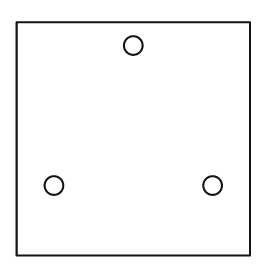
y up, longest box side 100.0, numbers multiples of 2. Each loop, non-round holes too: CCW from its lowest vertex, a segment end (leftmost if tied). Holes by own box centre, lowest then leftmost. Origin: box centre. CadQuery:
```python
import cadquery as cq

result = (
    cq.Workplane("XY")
    .moveTo(-50.0, -50.0)
    .lineTo(50.0, -50.0)
    .lineTo(50.0, 50.0)
    .lineTo(-50.0, 50.0)
    .close()
    .moveTo(-34.0, -20.0)
    .circle(4.0)
    .moveTo(34.0, -20.0)
    .circle(4.0)
    .moveTo(0.0, 40.0)
    .circle(4.0)
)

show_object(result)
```